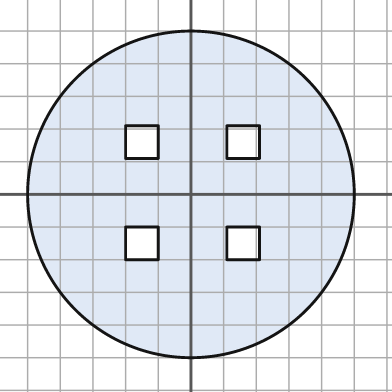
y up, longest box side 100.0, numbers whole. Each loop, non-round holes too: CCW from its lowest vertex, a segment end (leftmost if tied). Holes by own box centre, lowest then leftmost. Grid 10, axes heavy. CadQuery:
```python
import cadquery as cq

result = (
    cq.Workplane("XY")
    .moveTo(0.0, 0.0)
    .circle(50.0)
    .moveTo(-20.0, -20.0)
    .lineTo(-10.0, -20.0)
    .lineTo(-10.0, -10.0)
    .lineTo(-20.0, -10.0)
    .close()
    .moveTo(11.0, -20.0)
    .lineTo(21.0, -20.0)
    .lineTo(21.0, -10.0)
    .lineTo(11.0, -10.0)
    .close()
    .moveTo(-20.0, 11.0)
    .lineTo(-10.0, 11.0)
    .lineTo(-10.0, 21.0)
    .lineTo(-20.0, 21.0)
    .close()
    .moveTo(11.0, 11.0)
    .lineTo(21.0, 11.0)
    .lineTo(21.0, 21.0)
    .lineTo(11.0, 21.0)
    .close()
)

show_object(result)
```